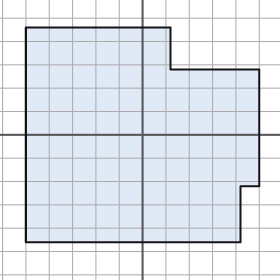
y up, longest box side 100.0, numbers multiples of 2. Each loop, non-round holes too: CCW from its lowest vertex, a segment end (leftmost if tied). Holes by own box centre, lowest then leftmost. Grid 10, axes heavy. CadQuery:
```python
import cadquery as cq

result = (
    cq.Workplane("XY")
    .moveTo(-50.0, -46.0)
    .lineTo(42.0, -46.0)
    .lineTo(42.0, -22.0)
    .lineTo(50.0, -22.0)
    .lineTo(50.0, 28.0)
    .lineTo(12.0, 28.0)
    .lineTo(12.0, 46.0)
    .lineTo(-50.0, 46.0)
    .close()
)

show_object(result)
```